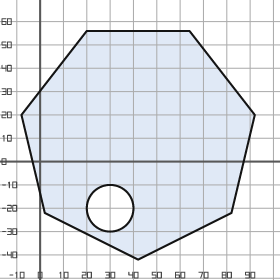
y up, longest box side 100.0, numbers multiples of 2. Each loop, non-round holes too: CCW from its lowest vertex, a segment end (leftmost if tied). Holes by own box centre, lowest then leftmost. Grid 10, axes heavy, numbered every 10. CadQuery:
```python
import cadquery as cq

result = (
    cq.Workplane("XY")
    .moveTo(42.0, -42.0)
    .lineTo(82.0, -22.0)
    .lineTo(92.0, 20.0)
    .lineTo(64.0, 56.0)
    .lineTo(20.0, 56.0)
    .lineTo(-8.0, 20.0)
    .lineTo(2.0, -22.0)
    .close()
    .moveTo(30.0, -20.0)
    .circle(10.0)
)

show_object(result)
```